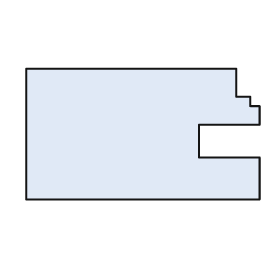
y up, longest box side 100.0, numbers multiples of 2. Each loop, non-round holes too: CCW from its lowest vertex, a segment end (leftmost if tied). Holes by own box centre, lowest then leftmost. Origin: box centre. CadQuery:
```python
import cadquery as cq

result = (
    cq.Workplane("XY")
    .moveTo(-50.0, -28.0)
    .lineTo(50.0, -28.0)
    .lineTo(50.0, -10.0)
    .lineTo(24.0, -10.0)
    .lineTo(24.0, 4.0)
    .lineTo(50.0, 4.0)
    .lineTo(50.0, 12.0)
    .lineTo(46.0, 12.0)
    .lineTo(46.0, 16.0)
    .lineTo(40.0, 16.0)
    .lineTo(40.0, 28.0)
    .lineTo(-50.0, 28.0)
    .close()
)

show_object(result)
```